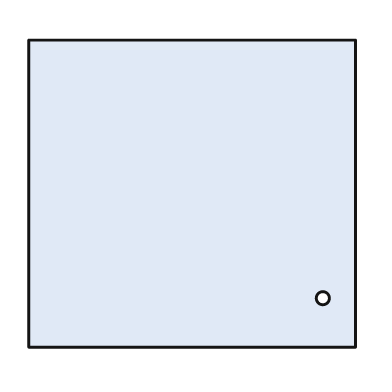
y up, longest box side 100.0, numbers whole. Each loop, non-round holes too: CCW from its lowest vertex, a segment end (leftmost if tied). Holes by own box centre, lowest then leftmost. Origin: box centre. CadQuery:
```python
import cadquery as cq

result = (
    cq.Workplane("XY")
    .moveTo(-50.0, -47.0)
    .lineTo(50.0, -47.0)
    .lineTo(50.0, 47.0)
    .lineTo(-50.0, 47.0)
    .close()
    .moveTo(40.0, -32.0)
    .circle(2.0)
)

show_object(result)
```